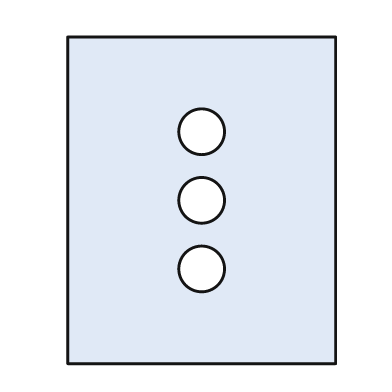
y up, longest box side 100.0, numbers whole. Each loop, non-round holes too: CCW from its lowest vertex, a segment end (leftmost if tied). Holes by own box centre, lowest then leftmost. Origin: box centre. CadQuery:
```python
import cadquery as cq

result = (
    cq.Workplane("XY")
    .moveTo(-41.0, -50.0)
    .lineTo(41.0, -50.0)
    .lineTo(41.0, 50.0)
    .lineTo(-41.0, 50.0)
    .close()
    .moveTo(0.0, -21.0)
    .circle(7.0)
    .moveTo(0.0, 0.0)
    .circle(7.0)
    .moveTo(0.0, 21.0)
    .circle(7.0)
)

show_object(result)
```